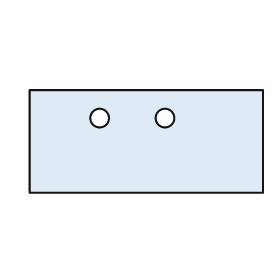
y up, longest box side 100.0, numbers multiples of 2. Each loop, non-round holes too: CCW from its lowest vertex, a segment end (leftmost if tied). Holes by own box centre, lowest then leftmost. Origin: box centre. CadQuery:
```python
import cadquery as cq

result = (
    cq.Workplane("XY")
    .moveTo(-50.0, -22.0)
    .lineTo(50.0, -22.0)
    .lineTo(50.0, 22.0)
    .lineTo(-50.0, 22.0)
    .close()
    .moveTo(-20.0, 10.0)
    .circle(4.0)
    .moveTo(8.0, 10.0)
    .circle(4.0)
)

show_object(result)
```